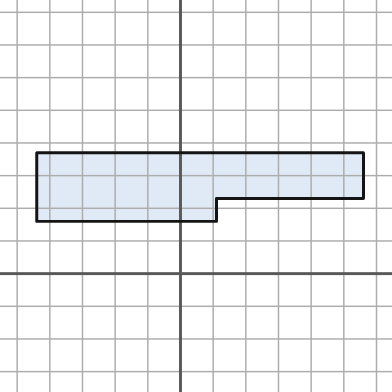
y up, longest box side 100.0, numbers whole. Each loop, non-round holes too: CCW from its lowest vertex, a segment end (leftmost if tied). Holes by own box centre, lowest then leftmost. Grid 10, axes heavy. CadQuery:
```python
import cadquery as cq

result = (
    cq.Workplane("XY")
    .moveTo(-44.0, 16.0)
    .lineTo(11.0, 16.0)
    .lineTo(11.0, 23.0)
    .lineTo(56.0, 23.0)
    .lineTo(56.0, 37.0)
    .lineTo(-44.0, 37.0)
    .close()
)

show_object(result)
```